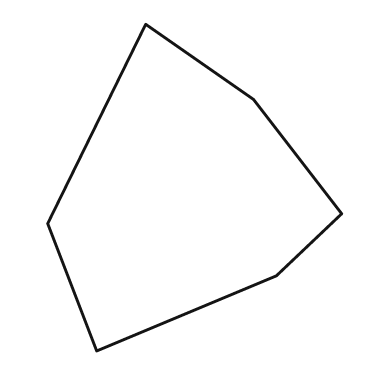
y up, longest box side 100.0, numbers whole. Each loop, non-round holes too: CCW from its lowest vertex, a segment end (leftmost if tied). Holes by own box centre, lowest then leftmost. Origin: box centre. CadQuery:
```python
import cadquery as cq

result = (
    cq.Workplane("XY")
    .moveTo(-30.0, -50.0)
    .lineTo(25.0, -27.0)
    .lineTo(45.0, -8.0)
    .lineTo(18.0, 27.0)
    .lineTo(-15.0, 50.0)
    .lineTo(-45.0, -11.0)
    .close()
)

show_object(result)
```